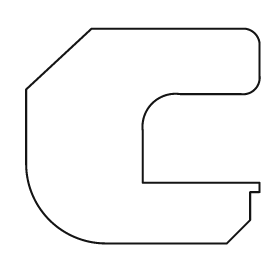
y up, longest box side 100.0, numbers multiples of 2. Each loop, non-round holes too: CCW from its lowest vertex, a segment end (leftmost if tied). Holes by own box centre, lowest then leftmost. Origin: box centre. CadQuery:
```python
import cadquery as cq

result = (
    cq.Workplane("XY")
    .moveTo(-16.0, -46.0)
    .lineTo(36.0, -46.0)
    .lineTo(46.0, -36.0)
    .lineTo(46.0, -24.0)
    .lineTo(50.0, -24.0)
    .lineTo(50.0, -20.0)
    .lineTo(0.0, -20.0)
    .lineTo(0.0, 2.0)
    .threePointArc((4.0, 14.0), (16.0, 18.0))
    .lineTo(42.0, 18.0)
    .threePointArc((48.0, 20.0), (50.0, 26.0))
    .lineTo(50.0, 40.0)
    .threePointArc((48.0, 44.0), (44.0, 46.0))
    .lineTo(-22.0, 46.0)
    .lineTo(-50.0, 20.0)
    .lineTo(-50.0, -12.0)
    .threePointArc((-40.0, -36.0), (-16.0, -46.0))
    .close()
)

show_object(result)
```